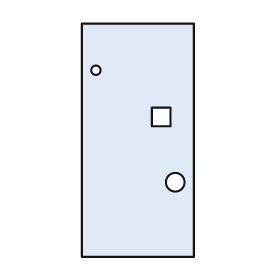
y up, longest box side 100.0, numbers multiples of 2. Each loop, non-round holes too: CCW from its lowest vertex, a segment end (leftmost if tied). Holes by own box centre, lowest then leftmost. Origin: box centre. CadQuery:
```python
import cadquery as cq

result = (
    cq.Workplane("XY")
    .moveTo(-24.0, -50.0)
    .lineTo(24.0, -50.0)
    .lineTo(24.0, 50.0)
    .lineTo(-24.0, 50.0)
    .close()
    .moveTo(16.0, -18.0)
    .circle(4.0)
    .moveTo(6.0, 6.0)
    .lineTo(14.0, 6.0)
    .lineTo(14.0, 14.0)
    .lineTo(6.0, 14.0)
    .close()
    .moveTo(-18.0, 30.0)
    .circle(2.0)
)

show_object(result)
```